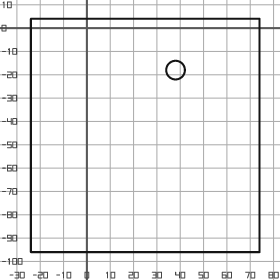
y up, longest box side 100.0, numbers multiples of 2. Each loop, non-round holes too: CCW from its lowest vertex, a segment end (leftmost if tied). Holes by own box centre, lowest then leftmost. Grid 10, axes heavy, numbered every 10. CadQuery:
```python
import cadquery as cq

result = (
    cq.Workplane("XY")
    .moveTo(-24.0, -96.0)
    .lineTo(74.0, -96.0)
    .lineTo(74.0, 4.0)
    .lineTo(-24.0, 4.0)
    .close()
    .moveTo(38.0, -18.0)
    .circle(4.0)
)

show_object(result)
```